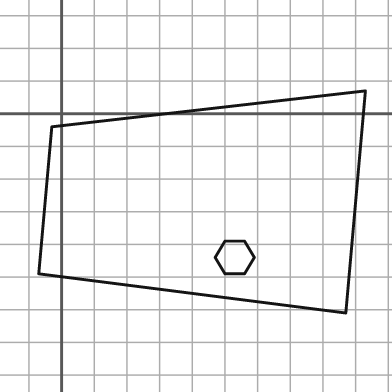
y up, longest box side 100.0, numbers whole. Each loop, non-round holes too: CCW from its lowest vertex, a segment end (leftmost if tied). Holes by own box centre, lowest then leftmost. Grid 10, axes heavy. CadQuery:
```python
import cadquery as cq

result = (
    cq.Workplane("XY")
    .moveTo(87.0, -61.0)
    .lineTo(93.0, 7.0)
    .lineTo(-3.0, -4.0)
    .lineTo(-7.0, -49.0)
    .close()
    .moveTo(50.0, -49.0)
    .lineTo(56.0, -49.0)
    .lineTo(59.0, -44.0)
    .lineTo(56.0, -39.0)
    .lineTo(50.0, -39.0)
    .lineTo(47.0, -44.0)
    .close()
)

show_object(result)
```